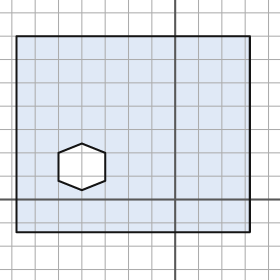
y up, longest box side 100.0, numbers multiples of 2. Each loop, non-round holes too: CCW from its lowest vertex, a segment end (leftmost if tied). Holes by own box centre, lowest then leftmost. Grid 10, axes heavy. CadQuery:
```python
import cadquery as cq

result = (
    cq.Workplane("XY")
    .moveTo(-68.0, -14.0)
    .lineTo(32.0, -14.0)
    .lineTo(32.0, 70.0)
    .lineTo(-68.0, 70.0)
    .close()
    .moveTo(-40.0, 4.0)
    .lineTo(-30.0, 8.0)
    .lineTo(-30.0, 20.0)
    .lineTo(-40.0, 24.0)
    .lineTo(-50.0, 20.0)
    .lineTo(-50.0, 8.0)
    .close()
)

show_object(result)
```